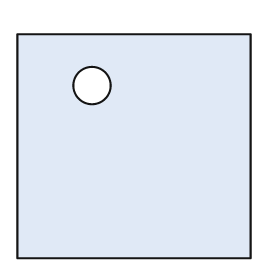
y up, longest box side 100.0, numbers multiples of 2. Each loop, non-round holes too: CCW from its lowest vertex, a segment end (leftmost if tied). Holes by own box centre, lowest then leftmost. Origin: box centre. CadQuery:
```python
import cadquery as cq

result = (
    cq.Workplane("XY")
    .moveTo(-50.0, -48.0)
    .lineTo(50.0, -48.0)
    .lineTo(50.0, 48.0)
    .lineTo(-50.0, 48.0)
    .close()
    .moveTo(-18.0, 26.0)
    .circle(8.0)
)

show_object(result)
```